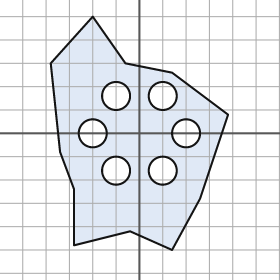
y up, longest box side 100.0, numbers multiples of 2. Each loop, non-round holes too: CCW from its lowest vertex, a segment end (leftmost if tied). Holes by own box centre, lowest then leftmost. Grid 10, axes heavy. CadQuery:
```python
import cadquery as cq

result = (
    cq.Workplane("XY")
    .moveTo(14.0, -50.0)
    .lineTo(26.0, -28.0)
    .lineTo(38.0, 8.0)
    .lineTo(14.0, 26.0)
    .lineTo(-6.0, 30.0)
    .lineTo(-20.0, 50.0)
    .lineTo(-38.0, 30.0)
    .lineTo(-34.0, -8.0)
    .lineTo(-28.0, -24.0)
    .lineTo(-28.0, -48.0)
    .lineTo(-4.0, -42.0)
    .close()
    .moveTo(-10.0, -16.0)
    .circle(6.0)
    .moveTo(10.0, -16.0)
    .circle(6.0)
    .moveTo(-20.0, 0.0)
    .circle(6.0)
    .moveTo(20.0, 0.0)
    .circle(6.0)
    .moveTo(-10.0, 16.0)
    .circle(6.0)
    .moveTo(10.0, 16.0)
    .circle(6.0)
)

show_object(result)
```